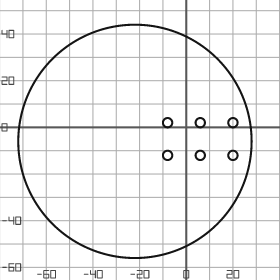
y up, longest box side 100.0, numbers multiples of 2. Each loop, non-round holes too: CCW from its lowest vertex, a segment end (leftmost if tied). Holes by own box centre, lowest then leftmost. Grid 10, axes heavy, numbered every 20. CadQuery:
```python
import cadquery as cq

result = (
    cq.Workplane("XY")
    .moveTo(-22.0, -6.0)
    .circle(50.0)
    .moveTo(-8.0, -12.0)
    .circle(2.0)
    .moveTo(6.0, -12.0)
    .circle(2.0)
    .moveTo(20.0, -12.0)
    .circle(2.0)
    .moveTo(-8.0, 2.0)
    .circle(2.0)
    .moveTo(6.0, 2.0)
    .circle(2.0)
    .moveTo(20.0, 2.0)
    .circle(2.0)
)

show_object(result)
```